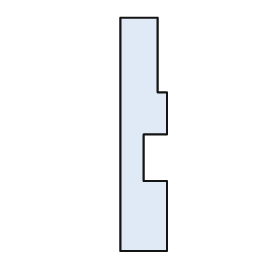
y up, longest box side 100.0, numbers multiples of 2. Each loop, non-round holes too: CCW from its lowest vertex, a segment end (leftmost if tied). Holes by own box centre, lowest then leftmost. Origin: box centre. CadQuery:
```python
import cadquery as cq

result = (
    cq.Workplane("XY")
    .moveTo(-10.0, -50.0)
    .lineTo(10.0, -50.0)
    .lineTo(10.0, -20.0)
    .lineTo(0.0, -20.0)
    .lineTo(0.0, 0.0)
    .lineTo(10.0, 0.0)
    .lineTo(10.0, 18.0)
    .lineTo(6.0, 18.0)
    .lineTo(6.0, 50.0)
    .lineTo(-10.0, 50.0)
    .close()
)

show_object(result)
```